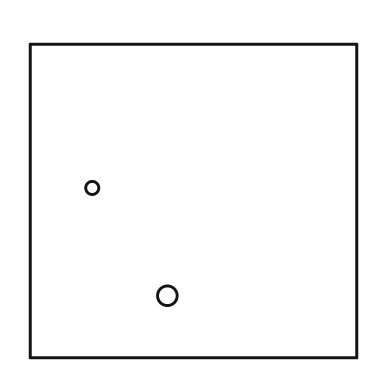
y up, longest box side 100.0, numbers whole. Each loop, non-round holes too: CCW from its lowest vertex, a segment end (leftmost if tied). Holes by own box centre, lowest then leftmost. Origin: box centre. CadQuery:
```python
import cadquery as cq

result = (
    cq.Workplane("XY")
    .moveTo(-50.0, -48.0)
    .lineTo(50.0, -48.0)
    .lineTo(50.0, 48.0)
    .lineTo(-50.0, 48.0)
    .close()
    .moveTo(-8.0, -29.0)
    .circle(3.0)
    .moveTo(-31.0, 4.0)
    .circle(2.0)
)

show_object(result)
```